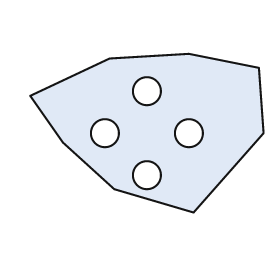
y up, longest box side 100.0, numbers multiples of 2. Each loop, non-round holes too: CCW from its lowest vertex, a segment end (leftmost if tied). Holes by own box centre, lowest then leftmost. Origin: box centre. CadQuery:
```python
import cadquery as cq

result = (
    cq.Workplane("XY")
    .moveTo(20.0, -34.0)
    .lineTo(50.0, 0.0)
    .lineTo(48.0, 28.0)
    .lineTo(18.0, 34.0)
    .lineTo(-16.0, 32.0)
    .lineTo(-50.0, 16.0)
    .lineTo(-36.0, -4.0)
    .lineTo(-14.0, -24.0)
    .close()
    .moveTo(0.0, -18.0)
    .circle(6.0)
    .moveTo(-18.0, 0.0)
    .circle(6.0)
    .moveTo(18.0, 0.0)
    .circle(6.0)
    .moveTo(0.0, 18.0)
    .circle(6.0)
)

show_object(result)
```